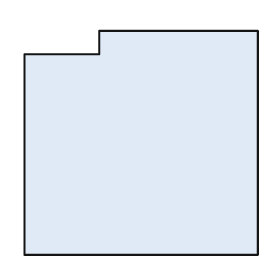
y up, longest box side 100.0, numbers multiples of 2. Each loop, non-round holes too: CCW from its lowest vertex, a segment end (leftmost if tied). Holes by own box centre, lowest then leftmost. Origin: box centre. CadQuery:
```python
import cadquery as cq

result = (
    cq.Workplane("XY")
    .moveTo(-50.0, -48.0)
    .lineTo(50.0, -48.0)
    .lineTo(50.0, 48.0)
    .lineTo(-18.0, 48.0)
    .lineTo(-18.0, 38.0)
    .lineTo(-50.0, 38.0)
    .close()
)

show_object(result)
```